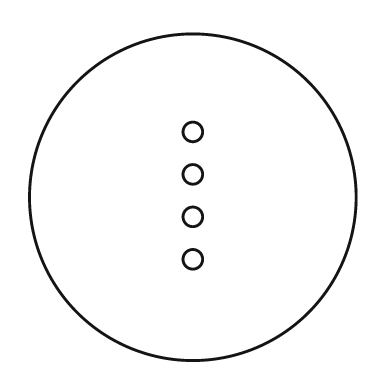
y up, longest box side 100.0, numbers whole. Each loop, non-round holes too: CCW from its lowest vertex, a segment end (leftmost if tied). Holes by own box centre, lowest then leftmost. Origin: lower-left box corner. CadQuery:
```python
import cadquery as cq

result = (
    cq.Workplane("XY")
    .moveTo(50.0, 50.0)
    .circle(50.0)
    .moveTo(50.0, 31.0)
    .circle(3.0)
    .moveTo(50.0, 44.0)
    .circle(3.0)
    .moveTo(50.0, 57.0)
    .circle(3.0)
    .moveTo(50.0, 70.0)
    .circle(3.0)
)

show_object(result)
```